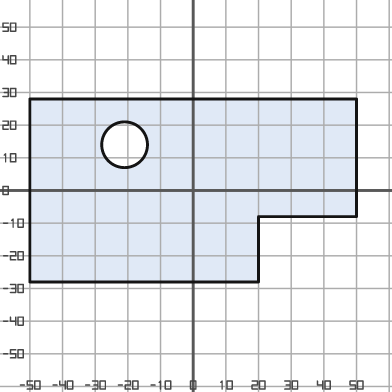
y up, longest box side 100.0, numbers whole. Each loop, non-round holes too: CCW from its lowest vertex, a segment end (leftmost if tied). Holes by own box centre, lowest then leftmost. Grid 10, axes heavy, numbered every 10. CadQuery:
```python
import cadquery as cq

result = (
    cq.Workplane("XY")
    .moveTo(-50.0, -28.0)
    .lineTo(20.0, -28.0)
    .lineTo(20.0, -8.0)
    .lineTo(50.0, -8.0)
    .lineTo(50.0, 28.0)
    .lineTo(-50.0, 28.0)
    .close()
    .moveTo(-21.0, 14.0)
    .circle(7.0)
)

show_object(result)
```